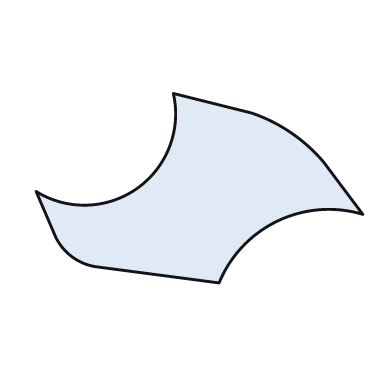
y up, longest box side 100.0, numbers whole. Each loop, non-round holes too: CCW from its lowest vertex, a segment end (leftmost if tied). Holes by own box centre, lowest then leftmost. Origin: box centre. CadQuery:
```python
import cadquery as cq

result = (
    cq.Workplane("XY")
    .moveTo(6.0, -29.0)
    .threePointArc((24.0, -10.0), (50.0, -8.0))
    .lineTo(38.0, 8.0)
    .threePointArc((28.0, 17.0), (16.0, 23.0))
    .lineTo(-8.0, 29.0)
    .threePointArc((-19.0, 0.0), (-50.0, -1.0))
    .lineTo(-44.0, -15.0)
    .threePointArc((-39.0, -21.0), (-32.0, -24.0))
    .close()
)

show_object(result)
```